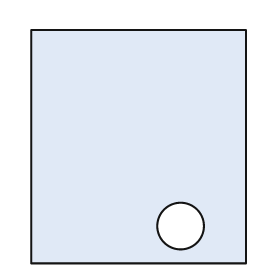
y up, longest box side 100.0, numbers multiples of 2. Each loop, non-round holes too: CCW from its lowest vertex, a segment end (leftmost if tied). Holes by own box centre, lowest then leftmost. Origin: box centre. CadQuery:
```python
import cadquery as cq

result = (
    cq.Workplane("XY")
    .moveTo(-46.0, -50.0)
    .lineTo(46.0, -50.0)
    .lineTo(46.0, 50.0)
    .lineTo(-46.0, 50.0)
    .close()
    .moveTo(18.0, -34.0)
    .circle(10.0)
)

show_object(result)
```